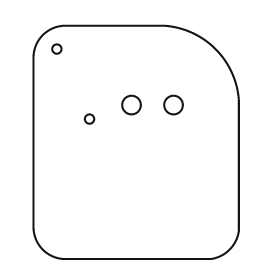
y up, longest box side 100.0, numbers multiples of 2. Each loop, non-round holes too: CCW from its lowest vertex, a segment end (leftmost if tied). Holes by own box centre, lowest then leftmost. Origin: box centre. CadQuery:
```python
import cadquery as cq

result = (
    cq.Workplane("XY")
    .moveTo(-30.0, -50.0)
    .lineTo(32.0, -50.0)
    .threePointArc((40.0, -46.0), (44.0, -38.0))
    .lineTo(44.0, 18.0)
    .threePointArc((34.0, 40.0), (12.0, 50.0))
    .lineTo(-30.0, 50.0)
    .threePointArc((-40.0, 46.0), (-44.0, 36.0))
    .lineTo(-44.0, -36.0)
    .threePointArc((-40.0, -46.0), (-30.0, -50.0))
    .close()
    .moveTo(-20.0, 10.0)
    .circle(2.0)
    .moveTo(-2.0, 16.0)
    .circle(4.0)
    .moveTo(16.0, 16.0)
    .circle(4.0)
    .moveTo(-34.0, 40.0)
    .circle(2.0)
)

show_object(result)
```